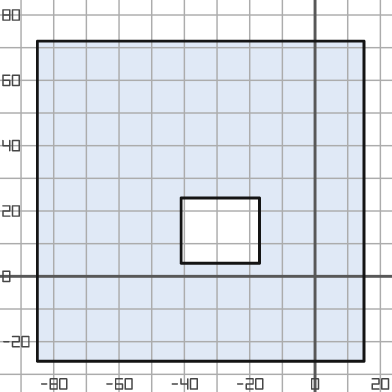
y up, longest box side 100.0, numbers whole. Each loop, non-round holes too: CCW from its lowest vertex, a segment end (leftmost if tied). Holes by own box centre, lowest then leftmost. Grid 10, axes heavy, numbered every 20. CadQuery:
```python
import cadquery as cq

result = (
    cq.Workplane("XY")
    .moveTo(-85.0, -26.0)
    .lineTo(15.0, -26.0)
    .lineTo(15.0, 72.0)
    .lineTo(-85.0, 72.0)
    .close()
    .moveTo(-41.0, 4.0)
    .lineTo(-17.0, 4.0)
    .lineTo(-17.0, 24.0)
    .lineTo(-41.0, 24.0)
    .close()
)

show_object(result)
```